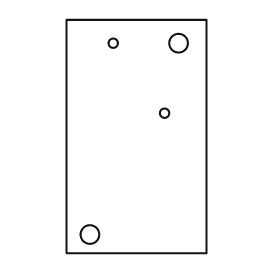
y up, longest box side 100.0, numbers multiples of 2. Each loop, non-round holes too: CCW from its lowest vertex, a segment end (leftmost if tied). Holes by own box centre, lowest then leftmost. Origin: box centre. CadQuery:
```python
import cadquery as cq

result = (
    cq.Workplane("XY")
    .moveTo(-30.0, -50.0)
    .lineTo(30.0, -50.0)
    .lineTo(30.0, 50.0)
    .lineTo(-30.0, 50.0)
    .close()
    .moveTo(-20.0, -42.0)
    .circle(4.0)
    .moveTo(12.0, 10.0)
    .circle(2.0)
    .moveTo(-10.0, 40.0)
    .circle(2.0)
    .moveTo(18.0, 40.0)
    .circle(4.0)
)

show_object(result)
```